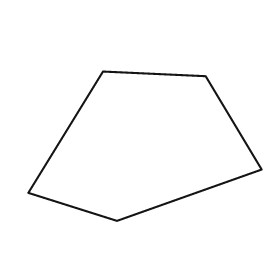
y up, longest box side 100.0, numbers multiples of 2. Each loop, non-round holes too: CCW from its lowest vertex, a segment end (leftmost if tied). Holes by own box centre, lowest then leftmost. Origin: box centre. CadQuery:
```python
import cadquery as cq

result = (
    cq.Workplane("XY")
    .moveTo(-12.0, -32.0)
    .lineTo(50.0, -10.0)
    .lineTo(26.0, 30.0)
    .lineTo(-18.0, 32.0)
    .lineTo(-50.0, -20.0)
    .close()
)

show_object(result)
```